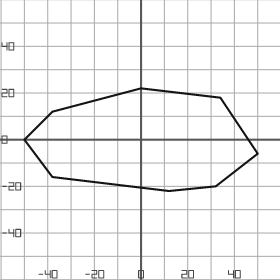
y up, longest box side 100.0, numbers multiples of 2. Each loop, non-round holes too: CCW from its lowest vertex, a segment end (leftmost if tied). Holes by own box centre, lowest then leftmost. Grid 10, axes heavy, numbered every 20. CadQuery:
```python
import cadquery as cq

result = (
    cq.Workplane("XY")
    .moveTo(12.0, -22.0)
    .lineTo(32.0, -20.0)
    .lineTo(50.0, -6.0)
    .lineTo(34.0, 18.0)
    .lineTo(0.0, 22.0)
    .lineTo(-38.0, 12.0)
    .lineTo(-50.0, 0.0)
    .lineTo(-38.0, -16.0)
    .close()
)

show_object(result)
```